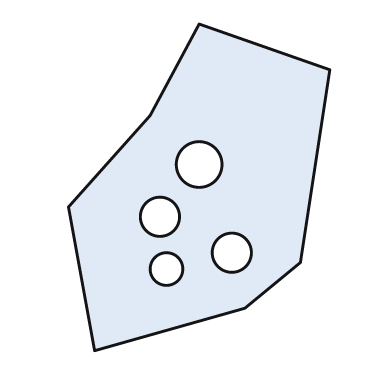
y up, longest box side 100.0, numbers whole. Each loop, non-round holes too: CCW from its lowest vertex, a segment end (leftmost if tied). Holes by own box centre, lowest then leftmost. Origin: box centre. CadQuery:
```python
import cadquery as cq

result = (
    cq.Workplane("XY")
    .moveTo(-32.0, -50.0)
    .lineTo(14.0, -37.0)
    .lineTo(31.0, -23.0)
    .lineTo(40.0, 36.0)
    .lineTo(0.0, 50.0)
    .lineTo(-15.0, 22.0)
    .lineTo(-40.0, -6.0)
    .close()
    .moveTo(-10.0, -25.0)
    .circle(5.0)
    .moveTo(10.0, -20.0)
    .circle(6.0)
    .moveTo(-12.0, -9.0)
    .circle(6.0)
    .moveTo(0.0, 7.0)
    .circle(7.0)
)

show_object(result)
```